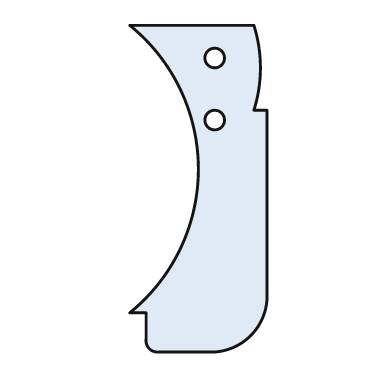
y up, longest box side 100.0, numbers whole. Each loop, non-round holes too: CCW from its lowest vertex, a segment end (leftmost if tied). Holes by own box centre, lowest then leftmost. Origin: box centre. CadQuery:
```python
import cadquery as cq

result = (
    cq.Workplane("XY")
    .moveTo(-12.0, -50.0)
    .lineTo(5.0, -50.0)
    .threePointArc((16.0, -45.0), (21.0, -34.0))
    .lineTo(21.0, 24.0)
    .lineTo(17.0, 24.0)
    .threePointArc((19.0, 37.0), (17.0, 50.0))
    .lineTo(-21.0, 50.0)
    .threePointArc((0.0, 6.0), (-21.0, -38.0))
    .lineTo(-16.0, -38.0)
    .lineTo(-16.0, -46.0)
    .threePointArc((-15.0, -49.0), (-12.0, -50.0))
    .close()
    .moveTo(5.0, 21.0)
    .circle(3.0)
    .moveTo(5.0, 40.0)
    .circle(3.0)
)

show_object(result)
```